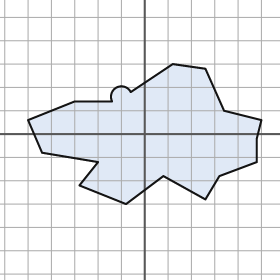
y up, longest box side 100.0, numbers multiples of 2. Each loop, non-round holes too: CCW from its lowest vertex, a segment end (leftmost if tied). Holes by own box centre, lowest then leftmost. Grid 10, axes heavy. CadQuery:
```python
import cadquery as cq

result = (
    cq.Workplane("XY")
    .moveTo(-8.0, -30.0)
    .lineTo(8.0, -18.0)
    .lineTo(26.0, -28.0)
    .lineTo(32.0, -18.0)
    .lineTo(48.0, -12.0)
    .lineTo(48.0, -2.0)
    .lineTo(50.0, 6.0)
    .lineTo(34.0, 10.0)
    .lineTo(26.0, 28.0)
    .lineTo(12.0, 30.0)
    .lineTo(-6.0, 18.0)
    .threePointArc((-12.0, 20.0), (-14.0, 14.0))
    .lineTo(-30.0, 14.0)
    .lineTo(-50.0, 6.0)
    .lineTo(-44.0, -8.0)
    .lineTo(-20.0, -12.0)
    .lineTo(-28.0, -22.0)
    .close()
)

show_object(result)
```